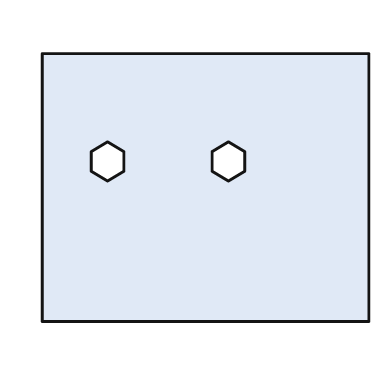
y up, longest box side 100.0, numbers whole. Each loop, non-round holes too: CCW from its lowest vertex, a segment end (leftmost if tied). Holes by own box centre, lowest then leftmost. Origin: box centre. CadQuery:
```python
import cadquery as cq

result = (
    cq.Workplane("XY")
    .moveTo(-50.0, -41.0)
    .lineTo(50.0, -41.0)
    .lineTo(50.0, 41.0)
    .lineTo(-50.0, 41.0)
    .close()
    .moveTo(-30.0, 2.0)
    .lineTo(-25.0, 5.0)
    .lineTo(-25.0, 11.0)
    .lineTo(-30.0, 14.0)
    .lineTo(-35.0, 11.0)
    .lineTo(-35.0, 5.0)
    .close()
    .moveTo(7.0, 2.0)
    .lineTo(12.0, 5.0)
    .lineTo(12.0, 11.0)
    .lineTo(7.0, 14.0)
    .lineTo(2.0, 11.0)
    .lineTo(2.0, 5.0)
    .close()
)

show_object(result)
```